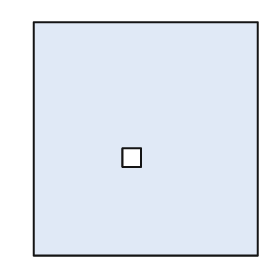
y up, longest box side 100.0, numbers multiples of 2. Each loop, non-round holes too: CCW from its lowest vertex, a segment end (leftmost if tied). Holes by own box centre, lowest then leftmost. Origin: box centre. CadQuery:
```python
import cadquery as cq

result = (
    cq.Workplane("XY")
    .moveTo(-48.0, -50.0)
    .lineTo(48.0, -50.0)
    .lineTo(48.0, 50.0)
    .lineTo(-48.0, 50.0)
    .close()
    .moveTo(-10.0, -12.0)
    .lineTo(-2.0, -12.0)
    .lineTo(-2.0, -4.0)
    .lineTo(-10.0, -4.0)
    .close()
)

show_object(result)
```